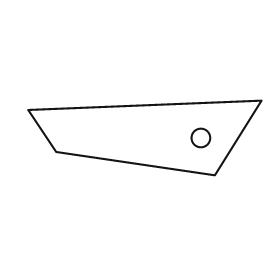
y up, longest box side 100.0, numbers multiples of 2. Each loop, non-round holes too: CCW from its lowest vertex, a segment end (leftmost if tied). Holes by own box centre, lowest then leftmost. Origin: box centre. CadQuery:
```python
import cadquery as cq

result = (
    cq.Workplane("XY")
    .moveTo(30.0, -16.0)
    .lineTo(50.0, 16.0)
    .lineTo(-50.0, 12.0)
    .lineTo(-38.0, -6.0)
    .close()
    .moveTo(24.0, 0.0)
    .circle(4.0)
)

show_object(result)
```